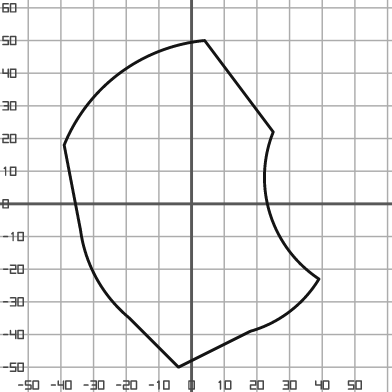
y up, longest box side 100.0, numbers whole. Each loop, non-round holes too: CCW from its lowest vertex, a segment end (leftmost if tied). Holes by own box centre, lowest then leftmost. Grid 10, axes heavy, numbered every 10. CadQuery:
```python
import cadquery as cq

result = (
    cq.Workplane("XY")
    .moveTo(-4.0, -50.0)
    .lineTo(18.0, -39.0)
    .threePointArc((30.0, -33.0), (39.0, -23.0))
    .threePointArc((24.0, -3.0), (25.0, 22.0))
    .lineTo(4.0, 50.0)
    .threePointArc((-22.0, 40.0), (-39.0, 18.0))
    .lineTo(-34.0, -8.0)
    .threePointArc((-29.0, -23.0), (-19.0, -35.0))
    .close()
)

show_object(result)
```